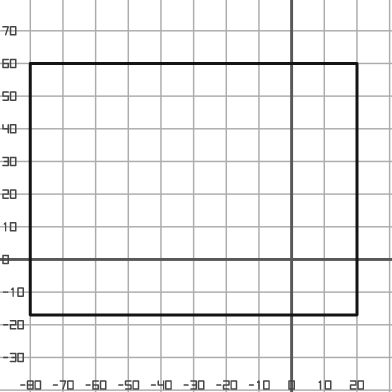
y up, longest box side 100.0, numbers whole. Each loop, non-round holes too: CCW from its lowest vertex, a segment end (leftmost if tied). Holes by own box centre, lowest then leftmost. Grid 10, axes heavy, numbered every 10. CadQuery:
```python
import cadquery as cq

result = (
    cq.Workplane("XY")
    .moveTo(-80.0, -17.0)
    .lineTo(20.0, -17.0)
    .lineTo(20.0, 60.0)
    .lineTo(-80.0, 60.0)
    .close()
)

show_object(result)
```